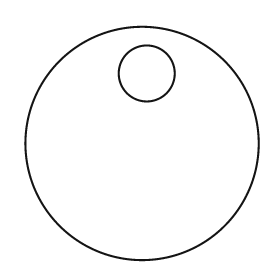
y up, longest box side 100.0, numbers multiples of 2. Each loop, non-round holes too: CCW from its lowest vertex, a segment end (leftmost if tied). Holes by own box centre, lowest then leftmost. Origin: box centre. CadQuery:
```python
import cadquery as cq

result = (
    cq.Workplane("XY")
    .moveTo(0.0, 0.0)
    .circle(50.0)
    .moveTo(2.0, 30.0)
    .circle(12.0)
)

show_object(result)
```